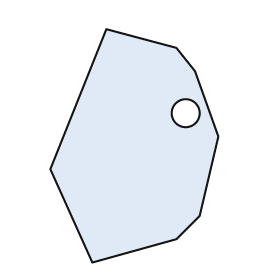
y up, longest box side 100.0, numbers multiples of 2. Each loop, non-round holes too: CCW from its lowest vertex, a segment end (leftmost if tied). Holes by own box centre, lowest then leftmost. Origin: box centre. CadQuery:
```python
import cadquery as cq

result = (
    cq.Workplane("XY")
    .moveTo(-18.0, -50.0)
    .lineTo(18.0, -40.0)
    .lineTo(28.0, -30.0)
    .lineTo(36.0, 4.0)
    .lineTo(26.0, 32.0)
    .lineTo(18.0, 42.0)
    .lineTo(-12.0, 50.0)
    .lineTo(-36.0, -10.0)
    .close()
    .moveTo(22.0, 14.0)
    .circle(6.0)
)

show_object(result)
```